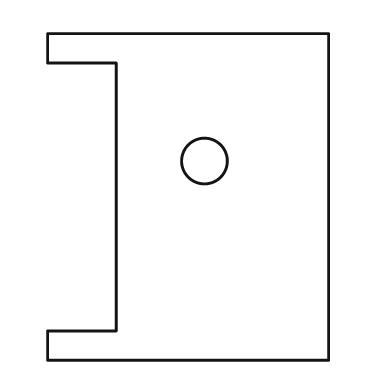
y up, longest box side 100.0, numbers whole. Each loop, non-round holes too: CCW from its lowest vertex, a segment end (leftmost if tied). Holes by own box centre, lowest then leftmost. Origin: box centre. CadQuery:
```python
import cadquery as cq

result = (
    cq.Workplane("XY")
    .moveTo(-43.0, -50.0)
    .lineTo(43.0, -50.0)
    .lineTo(43.0, 50.0)
    .lineTo(-43.0, 50.0)
    .lineTo(-43.0, 41.0)
    .lineTo(-22.0, 41.0)
    .lineTo(-22.0, -41.0)
    .lineTo(-43.0, -41.0)
    .close()
    .moveTo(5.0, 11.0)
    .circle(7.0)
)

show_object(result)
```